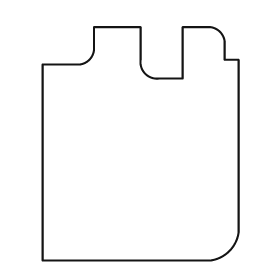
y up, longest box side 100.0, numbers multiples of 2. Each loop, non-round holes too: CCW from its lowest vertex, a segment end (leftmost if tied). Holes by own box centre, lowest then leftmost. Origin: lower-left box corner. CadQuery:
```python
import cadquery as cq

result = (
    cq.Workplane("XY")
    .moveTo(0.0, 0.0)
    .lineTo(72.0, 0.0)
    .threePointArc((80.0, 4.0), (84.0, 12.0))
    .lineTo(84.0, 86.0)
    .lineTo(78.0, 86.0)
    .lineTo(78.0, 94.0)
    .threePointArc((76.0, 98.0), (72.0, 100.0))
    .lineTo(60.0, 100.0)
    .lineTo(60.0, 78.0)
    .lineTo(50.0, 78.0)
    .threePointArc((44.0, 80.0), (42.0, 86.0))
    .lineTo(42.0, 100.0)
    .lineTo(22.0, 100.0)
    .lineTo(22.0, 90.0)
    .threePointArc((20.0, 86.0), (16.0, 84.0))
    .lineTo(0.0, 84.0)
    .close()
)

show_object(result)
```